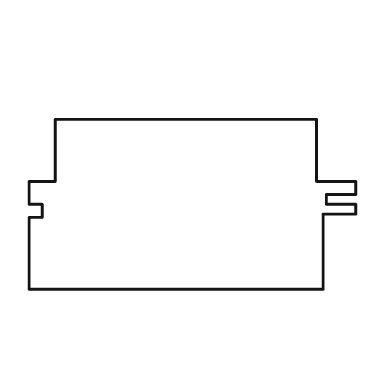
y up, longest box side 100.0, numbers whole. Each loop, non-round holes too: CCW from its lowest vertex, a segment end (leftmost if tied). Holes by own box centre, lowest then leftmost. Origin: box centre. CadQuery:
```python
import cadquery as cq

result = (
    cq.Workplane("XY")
    .moveTo(-50.0, -26.0)
    .lineTo(40.0, -26.0)
    .lineTo(40.0, -3.0)
    .lineTo(50.0, -3.0)
    .lineTo(50.0, 0.0)
    .lineTo(41.0, 0.0)
    .lineTo(41.0, 3.0)
    .lineTo(50.0, 3.0)
    .lineTo(50.0, 7.0)
    .lineTo(38.0, 7.0)
    .lineTo(38.0, 26.0)
    .lineTo(-42.0, 26.0)
    .lineTo(-42.0, 7.0)
    .lineTo(-50.0, 7.0)
    .lineTo(-50.0, 0.0)
    .lineTo(-46.0, 0.0)
    .lineTo(-46.0, -4.0)
    .lineTo(-50.0, -4.0)
    .close()
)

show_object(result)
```